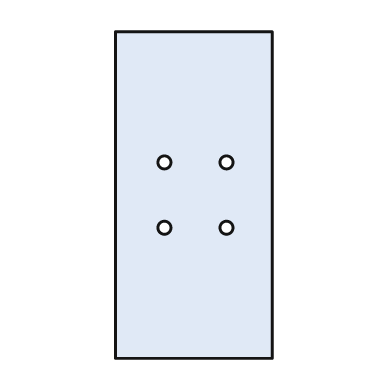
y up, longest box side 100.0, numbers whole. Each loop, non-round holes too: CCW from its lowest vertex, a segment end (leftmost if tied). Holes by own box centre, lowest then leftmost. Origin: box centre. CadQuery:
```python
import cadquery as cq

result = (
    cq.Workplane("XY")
    .moveTo(-24.0, -50.0)
    .lineTo(24.0, -50.0)
    .lineTo(24.0, 50.0)
    .lineTo(-24.0, 50.0)
    .close()
    .moveTo(-9.0, -10.0)
    .circle(2.0)
    .moveTo(10.0, -10.0)
    .circle(2.0)
    .moveTo(-9.0, 10.0)
    .circle(2.0)
    .moveTo(10.0, 10.0)
    .circle(2.0)
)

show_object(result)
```